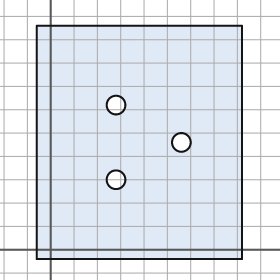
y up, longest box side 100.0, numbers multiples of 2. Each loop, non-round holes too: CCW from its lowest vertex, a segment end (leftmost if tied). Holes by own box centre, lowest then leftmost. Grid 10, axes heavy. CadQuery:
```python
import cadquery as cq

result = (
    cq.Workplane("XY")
    .moveTo(-6.0, -4.0)
    .lineTo(82.0, -4.0)
    .lineTo(82.0, 96.0)
    .lineTo(-6.0, 96.0)
    .close()
    .moveTo(28.0, 30.0)
    .circle(4.0)
    .moveTo(56.0, 46.0)
    .circle(4.0)
    .moveTo(28.0, 62.0)
    .circle(4.0)
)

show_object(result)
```